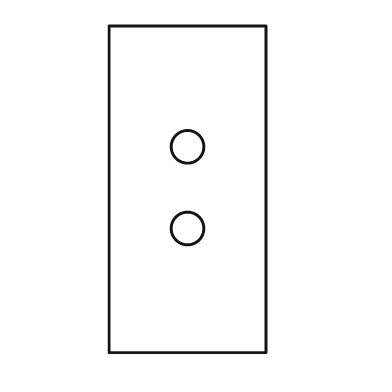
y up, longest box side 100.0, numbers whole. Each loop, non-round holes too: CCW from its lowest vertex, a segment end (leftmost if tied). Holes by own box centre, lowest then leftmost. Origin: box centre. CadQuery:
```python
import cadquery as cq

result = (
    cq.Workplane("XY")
    .moveTo(-24.0, -50.0)
    .lineTo(24.0, -50.0)
    .lineTo(24.0, 50.0)
    .lineTo(-24.0, 50.0)
    .close()
    .moveTo(0.0, -12.0)
    .circle(5.0)
    .moveTo(0.0, 13.0)
    .circle(5.0)
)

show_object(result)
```